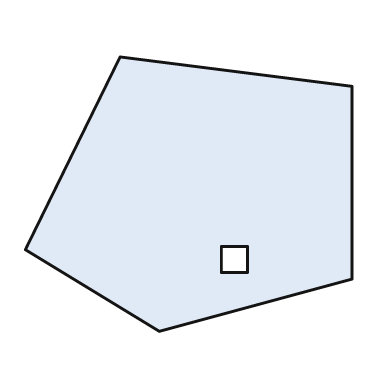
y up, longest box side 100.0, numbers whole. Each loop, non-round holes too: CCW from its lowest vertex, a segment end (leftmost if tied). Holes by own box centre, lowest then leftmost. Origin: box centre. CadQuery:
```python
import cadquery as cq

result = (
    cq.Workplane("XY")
    .moveTo(-9.0, -42.0)
    .lineTo(50.0, -26.0)
    .lineTo(50.0, 33.0)
    .lineTo(-21.0, 42.0)
    .lineTo(-50.0, -17.0)
    .close()
    .moveTo(10.0, -24.0)
    .lineTo(18.0, -24.0)
    .lineTo(18.0, -16.0)
    .lineTo(10.0, -16.0)
    .close()
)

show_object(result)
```